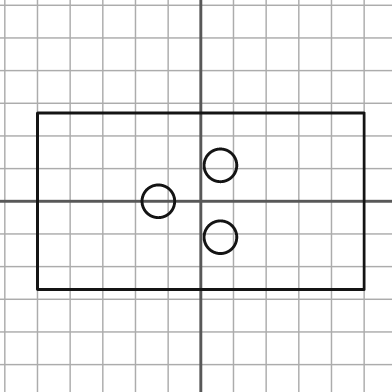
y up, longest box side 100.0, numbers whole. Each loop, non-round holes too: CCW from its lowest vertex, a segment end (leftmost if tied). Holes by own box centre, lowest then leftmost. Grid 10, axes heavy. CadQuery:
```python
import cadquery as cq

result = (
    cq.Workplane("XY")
    .moveTo(-50.0, -27.0)
    .lineTo(50.0, -27.0)
    .lineTo(50.0, 27.0)
    .lineTo(-50.0, 27.0)
    .close()
    .moveTo(6.0, -11.0)
    .circle(5.0)
    .moveTo(-13.0, 0.0)
    .circle(5.0)
    .moveTo(6.0, 11.0)
    .circle(5.0)
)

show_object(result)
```